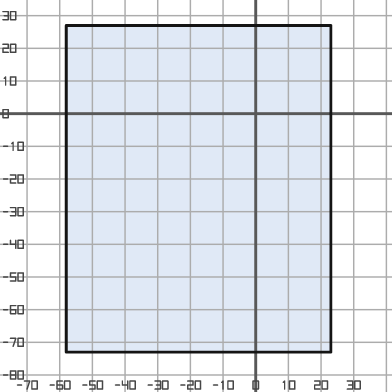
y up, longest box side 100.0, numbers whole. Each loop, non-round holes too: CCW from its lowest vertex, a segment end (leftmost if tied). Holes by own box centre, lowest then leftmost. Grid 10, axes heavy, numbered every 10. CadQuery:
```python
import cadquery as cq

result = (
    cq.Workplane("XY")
    .moveTo(-58.0, -73.0)
    .lineTo(23.0, -73.0)
    .lineTo(23.0, 27.0)
    .lineTo(-58.0, 27.0)
    .close()
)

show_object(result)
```